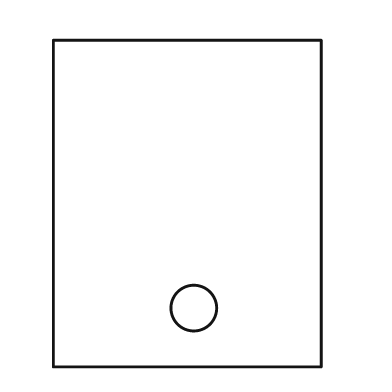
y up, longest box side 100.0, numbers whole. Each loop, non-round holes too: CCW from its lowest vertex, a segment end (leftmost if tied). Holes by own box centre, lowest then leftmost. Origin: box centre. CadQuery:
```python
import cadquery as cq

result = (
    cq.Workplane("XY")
    .moveTo(-41.0, -50.0)
    .lineTo(41.0, -50.0)
    .lineTo(41.0, 50.0)
    .lineTo(-41.0, 50.0)
    .close()
    .moveTo(2.0, -32.0)
    .circle(7.0)
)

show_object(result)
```